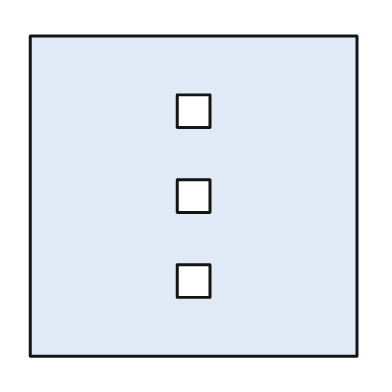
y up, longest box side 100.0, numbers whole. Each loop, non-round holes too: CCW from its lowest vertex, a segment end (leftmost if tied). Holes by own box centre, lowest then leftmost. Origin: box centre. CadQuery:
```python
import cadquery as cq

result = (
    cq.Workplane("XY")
    .moveTo(-50.0, -49.0)
    .lineTo(50.0, -49.0)
    .lineTo(50.0, 49.0)
    .lineTo(-50.0, 49.0)
    .close()
    .moveTo(-5.0, -31.0)
    .lineTo(5.0, -31.0)
    .lineTo(5.0, -21.0)
    .lineTo(-5.0, -21.0)
    .close()
    .moveTo(-5.0, -5.0)
    .lineTo(5.0, -5.0)
    .lineTo(5.0, 5.0)
    .lineTo(-5.0, 5.0)
    .close()
    .moveTo(-5.0, 21.0)
    .lineTo(5.0, 21.0)
    .lineTo(5.0, 31.0)
    .lineTo(-5.0, 31.0)
    .close()
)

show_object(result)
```